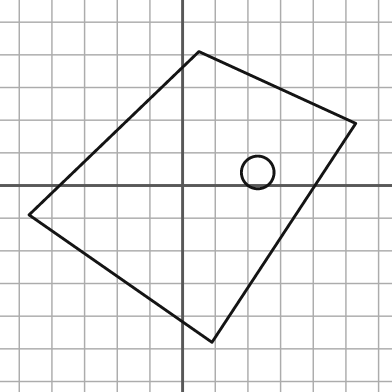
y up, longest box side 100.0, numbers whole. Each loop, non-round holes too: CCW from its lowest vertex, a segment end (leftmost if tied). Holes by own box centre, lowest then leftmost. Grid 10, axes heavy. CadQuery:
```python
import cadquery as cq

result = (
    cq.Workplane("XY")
    .moveTo(9.0, -48.0)
    .lineTo(53.0, 19.0)
    .lineTo(5.0, 41.0)
    .lineTo(-47.0, -9.0)
    .close()
    .moveTo(23.0, 4.0)
    .circle(5.0)
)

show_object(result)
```